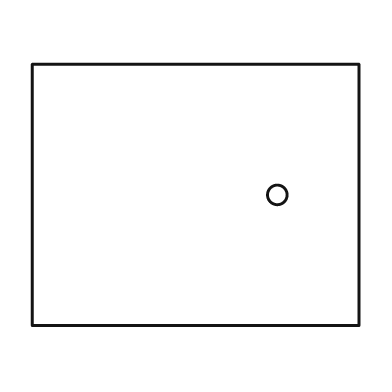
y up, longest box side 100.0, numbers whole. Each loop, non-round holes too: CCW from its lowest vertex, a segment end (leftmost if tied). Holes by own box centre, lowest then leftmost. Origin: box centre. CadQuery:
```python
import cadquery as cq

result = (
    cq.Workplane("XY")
    .moveTo(-50.0, -40.0)
    .lineTo(50.0, -40.0)
    .lineTo(50.0, 40.0)
    .lineTo(-50.0, 40.0)
    .close()
    .moveTo(25.0, 0.0)
    .circle(3.0)
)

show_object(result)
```